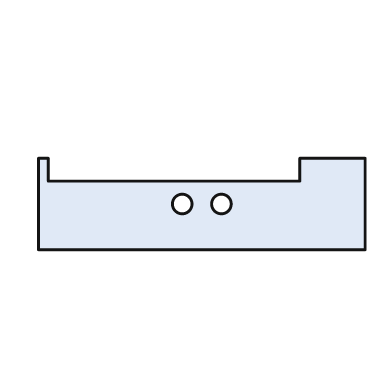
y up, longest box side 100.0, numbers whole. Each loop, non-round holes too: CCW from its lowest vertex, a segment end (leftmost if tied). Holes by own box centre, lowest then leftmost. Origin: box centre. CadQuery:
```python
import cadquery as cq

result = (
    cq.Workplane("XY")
    .moveTo(-50.0, -14.0)
    .lineTo(50.0, -14.0)
    .lineTo(50.0, 14.0)
    .lineTo(30.0, 14.0)
    .lineTo(30.0, 7.0)
    .lineTo(-47.0, 7.0)
    .lineTo(-47.0, 14.0)
    .lineTo(-50.0, 14.0)
    .close()
    .moveTo(-6.0, 0.0)
    .circle(3.0)
    .moveTo(6.0, 0.0)
    .circle(3.0)
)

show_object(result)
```